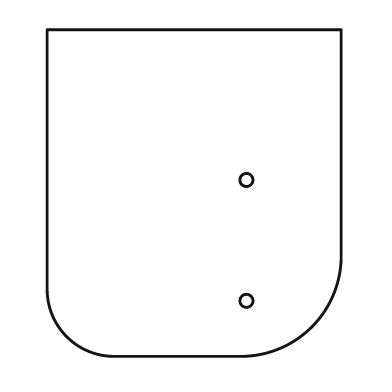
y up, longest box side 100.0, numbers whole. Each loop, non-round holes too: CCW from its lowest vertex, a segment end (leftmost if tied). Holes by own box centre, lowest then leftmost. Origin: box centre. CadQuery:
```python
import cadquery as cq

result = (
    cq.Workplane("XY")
    .moveTo(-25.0, -50.0)
    .lineTo(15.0, -50.0)
    .threePointArc((36.0, -41.0), (45.0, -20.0))
    .lineTo(45.0, 50.0)
    .lineTo(-45.0, 50.0)
    .lineTo(-45.0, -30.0)
    .threePointArc((-39.0, -44.0), (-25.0, -50.0))
    .close()
    .moveTo(16.0, -33.0)
    .circle(2.0)
    .moveTo(16.0, 4.0)
    .circle(2.0)
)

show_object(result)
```